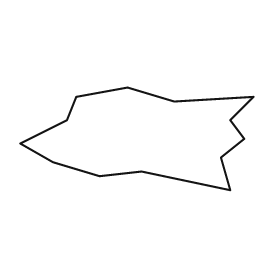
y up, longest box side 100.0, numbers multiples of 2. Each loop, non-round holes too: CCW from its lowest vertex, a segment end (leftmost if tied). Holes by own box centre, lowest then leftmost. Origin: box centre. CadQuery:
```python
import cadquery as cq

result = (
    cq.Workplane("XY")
    .moveTo(40.0, -22.0)
    .lineTo(36.0, -8.0)
    .lineTo(46.0, 0.0)
    .lineTo(40.0, 8.0)
    .lineTo(50.0, 18.0)
    .lineTo(16.0, 16.0)
    .lineTo(-4.0, 22.0)
    .lineTo(-26.0, 18.0)
    .lineTo(-30.0, 8.0)
    .lineTo(-50.0, -2.0)
    .lineTo(-36.0, -10.0)
    .lineTo(-16.0, -16.0)
    .lineTo(2.0, -14.0)
    .close()
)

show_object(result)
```